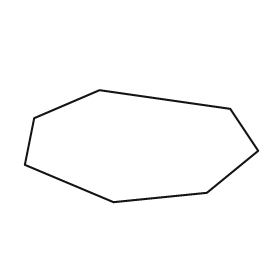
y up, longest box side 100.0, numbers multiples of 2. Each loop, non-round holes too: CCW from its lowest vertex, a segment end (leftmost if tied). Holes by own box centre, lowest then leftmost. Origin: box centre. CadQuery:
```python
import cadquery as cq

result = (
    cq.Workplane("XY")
    .moveTo(-12.0, -24.0)
    .lineTo(28.0, -20.0)
    .lineTo(50.0, -2.0)
    .lineTo(38.0, 16.0)
    .lineTo(-18.0, 24.0)
    .lineTo(-46.0, 12.0)
    .lineTo(-50.0, -8.0)
    .close()
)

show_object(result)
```